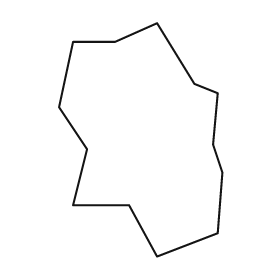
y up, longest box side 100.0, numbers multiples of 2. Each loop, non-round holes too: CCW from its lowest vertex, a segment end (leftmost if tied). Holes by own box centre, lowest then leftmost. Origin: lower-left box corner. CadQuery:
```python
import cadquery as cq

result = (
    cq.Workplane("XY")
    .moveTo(42.0, 0.0)
    .lineTo(68.0, 10.0)
    .lineTo(70.0, 36.0)
    .lineTo(66.0, 48.0)
    .lineTo(68.0, 70.0)
    .lineTo(58.0, 74.0)
    .lineTo(42.0, 100.0)
    .lineTo(24.0, 92.0)
    .lineTo(6.0, 92.0)
    .lineTo(0.0, 64.0)
    .lineTo(12.0, 46.0)
    .lineTo(6.0, 22.0)
    .lineTo(30.0, 22.0)
    .close()
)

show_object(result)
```